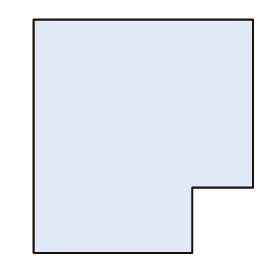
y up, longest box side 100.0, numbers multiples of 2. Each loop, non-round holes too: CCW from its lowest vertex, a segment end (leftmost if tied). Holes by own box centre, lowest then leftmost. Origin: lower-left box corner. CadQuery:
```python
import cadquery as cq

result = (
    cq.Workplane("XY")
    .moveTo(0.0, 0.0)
    .lineTo(68.0, 0.0)
    .lineTo(68.0, 28.0)
    .lineTo(94.0, 28.0)
    .lineTo(94.0, 100.0)
    .lineTo(0.0, 100.0)
    .close()
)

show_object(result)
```